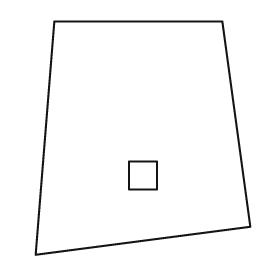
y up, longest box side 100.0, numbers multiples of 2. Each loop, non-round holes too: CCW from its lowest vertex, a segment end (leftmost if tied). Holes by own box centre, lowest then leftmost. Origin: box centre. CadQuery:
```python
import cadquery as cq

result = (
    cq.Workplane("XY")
    .moveTo(-46.0, -50.0)
    .lineTo(46.0, -38.0)
    .lineTo(34.0, 50.0)
    .lineTo(-38.0, 50.0)
    .close()
    .moveTo(-6.0, -22.0)
    .lineTo(6.0, -22.0)
    .lineTo(6.0, -10.0)
    .lineTo(-6.0, -10.0)
    .close()
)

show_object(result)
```